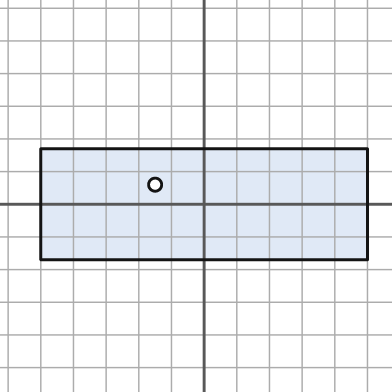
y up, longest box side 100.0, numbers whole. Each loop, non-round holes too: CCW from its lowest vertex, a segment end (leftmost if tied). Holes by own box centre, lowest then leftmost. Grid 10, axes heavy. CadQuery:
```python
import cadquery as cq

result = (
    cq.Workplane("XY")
    .moveTo(-50.0, -17.0)
    .lineTo(50.0, -17.0)
    .lineTo(50.0, 17.0)
    .lineTo(-50.0, 17.0)
    .close()
    .moveTo(-15.0, 6.0)
    .circle(2.0)
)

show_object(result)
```